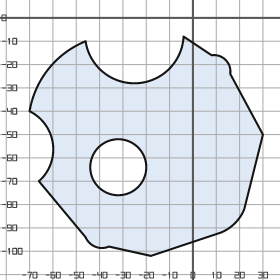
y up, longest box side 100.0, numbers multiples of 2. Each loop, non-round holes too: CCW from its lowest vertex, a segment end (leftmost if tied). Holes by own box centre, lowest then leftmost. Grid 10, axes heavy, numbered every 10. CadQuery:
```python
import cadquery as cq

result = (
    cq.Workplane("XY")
    .moveTo(-18.0, -102.0)
    .lineTo(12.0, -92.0)
    .threePointArc((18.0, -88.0), (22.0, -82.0))
    .lineTo(30.0, -50.0)
    .lineTo(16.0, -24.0)
    .threePointArc((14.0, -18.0), (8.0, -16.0))
    .lineTo(-4.0, -8.0)
    .threePointArc((-24.0, -28.0), (-46.0, -10.0))
    .threePointArc((-62.0, -22.0), (-70.0, -40.0))
    .threePointArc((-60.0, -54.0), (-66.0, -70.0))
    .lineTo(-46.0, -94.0)
    .threePointArc((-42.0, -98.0), (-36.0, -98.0))
    .close()
    .moveTo(-32.0, -64.0)
    .circle(12.0)
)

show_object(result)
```